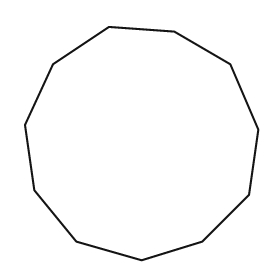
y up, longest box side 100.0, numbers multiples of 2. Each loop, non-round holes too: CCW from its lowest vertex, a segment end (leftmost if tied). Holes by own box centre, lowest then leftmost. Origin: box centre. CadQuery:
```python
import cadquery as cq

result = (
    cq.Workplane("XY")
    .moveTo(0.0, -50.0)
    .lineTo(26.0, -42.0)
    .lineTo(46.0, -22.0)
    .lineTo(50.0, 6.0)
    .lineTo(38.0, 34.0)
    .lineTo(14.0, 48.0)
    .lineTo(-14.0, 50.0)
    .lineTo(-38.0, 34.0)
    .lineTo(-50.0, 8.0)
    .lineTo(-46.0, -20.0)
    .lineTo(-28.0, -42.0)
    .close()
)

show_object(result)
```